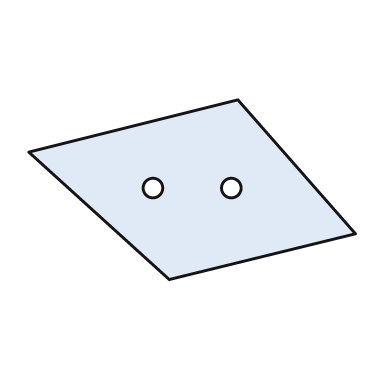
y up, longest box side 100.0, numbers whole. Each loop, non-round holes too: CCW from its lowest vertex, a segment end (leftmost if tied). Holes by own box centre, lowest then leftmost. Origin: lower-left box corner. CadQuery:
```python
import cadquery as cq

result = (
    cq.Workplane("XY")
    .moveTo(43.0, 0.0)
    .lineTo(100.0, 14.0)
    .lineTo(64.0, 55.0)
    .lineTo(0.0, 39.0)
    .close()
    .moveTo(38.0, 28.0)
    .circle(3.0)
    .moveTo(62.0, 28.0)
    .circle(3.0)
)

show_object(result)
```